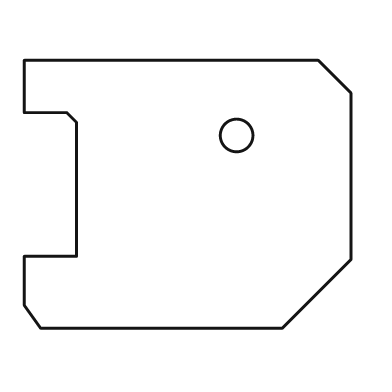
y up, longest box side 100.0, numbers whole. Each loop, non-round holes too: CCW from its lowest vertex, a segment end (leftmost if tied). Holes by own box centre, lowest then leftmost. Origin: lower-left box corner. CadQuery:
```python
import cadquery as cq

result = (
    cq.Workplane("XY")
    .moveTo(5.0, 0.0)
    .lineTo(79.0, 0.0)
    .lineTo(100.0, 21.0)
    .lineTo(100.0, 72.0)
    .lineTo(90.0, 82.0)
    .lineTo(0.0, 82.0)
    .lineTo(0.0, 66.0)
    .lineTo(13.0, 66.0)
    .lineTo(16.0, 63.0)
    .lineTo(16.0, 22.0)
    .lineTo(0.0, 22.0)
    .lineTo(0.0, 7.0)
    .close()
    .moveTo(65.0, 59.0)
    .circle(5.0)
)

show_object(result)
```